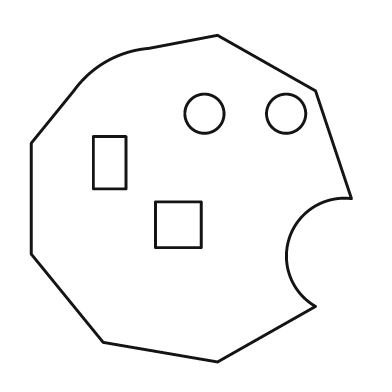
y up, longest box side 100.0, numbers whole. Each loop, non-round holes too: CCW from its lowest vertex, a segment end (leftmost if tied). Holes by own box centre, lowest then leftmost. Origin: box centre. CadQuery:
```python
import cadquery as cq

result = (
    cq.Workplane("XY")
    .moveTo(8.0, -50.0)
    .lineTo(38.0, -33.0)
    .threePointArc((30.0, -12.0), (49.0, 0.0))
    .lineTo(38.0, 33.0)
    .lineTo(8.0, 50.0)
    .lineTo(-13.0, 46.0)
    .threePointArc((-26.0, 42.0), (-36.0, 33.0))
    .lineTo(-49.0, 17.0)
    .lineTo(-49.0, -17.0)
    .lineTo(-27.0, -44.0)
    .close()
    .moveTo(-11.0, -15.0)
    .lineTo(3.0, -15.0)
    .lineTo(3.0, -1.0)
    .lineTo(-11.0, -1.0)
    .close()
    .moveTo(-30.0, 3.0)
    .lineTo(-20.0, 3.0)
    .lineTo(-20.0, 19.0)
    .lineTo(-30.0, 19.0)
    .close()
    .moveTo(4.0, 26.0)
    .circle(6.0)
    .moveTo(29.0, 26.0)
    .circle(6.0)
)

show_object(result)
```